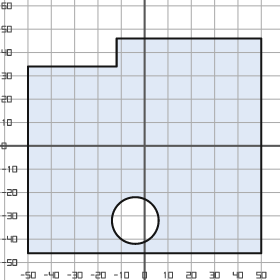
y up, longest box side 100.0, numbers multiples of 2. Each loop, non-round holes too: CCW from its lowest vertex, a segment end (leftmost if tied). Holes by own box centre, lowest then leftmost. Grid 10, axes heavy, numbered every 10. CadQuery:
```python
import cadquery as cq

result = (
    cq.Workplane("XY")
    .moveTo(-50.0, -46.0)
    .lineTo(50.0, -46.0)
    .lineTo(50.0, 46.0)
    .lineTo(-12.0, 46.0)
    .lineTo(-12.0, 34.0)
    .lineTo(-50.0, 34.0)
    .close()
    .moveTo(-4.0, -32.0)
    .circle(10.0)
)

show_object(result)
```